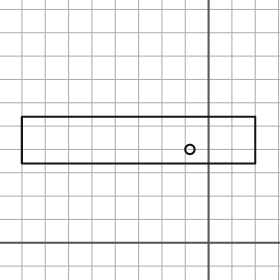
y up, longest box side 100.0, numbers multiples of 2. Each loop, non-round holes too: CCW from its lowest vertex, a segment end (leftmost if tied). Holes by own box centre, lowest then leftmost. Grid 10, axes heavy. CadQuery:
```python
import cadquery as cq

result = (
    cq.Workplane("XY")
    .moveTo(-80.0, 34.0)
    .lineTo(20.0, 34.0)
    .lineTo(20.0, 54.0)
    .lineTo(-80.0, 54.0)
    .close()
    .moveTo(-8.0, 40.0)
    .circle(2.0)
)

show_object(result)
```